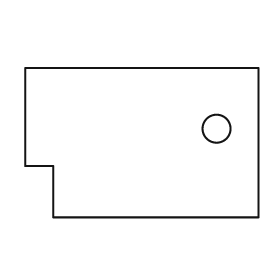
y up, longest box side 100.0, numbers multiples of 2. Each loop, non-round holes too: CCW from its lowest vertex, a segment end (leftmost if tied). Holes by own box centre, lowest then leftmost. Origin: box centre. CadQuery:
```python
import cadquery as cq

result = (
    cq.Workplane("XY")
    .moveTo(-38.0, -32.0)
    .lineTo(50.0, -32.0)
    .lineTo(50.0, 32.0)
    .lineTo(-50.0, 32.0)
    .lineTo(-50.0, -10.0)
    .lineTo(-38.0, -10.0)
    .close()
    .moveTo(32.0, 6.0)
    .circle(6.0)
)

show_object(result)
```